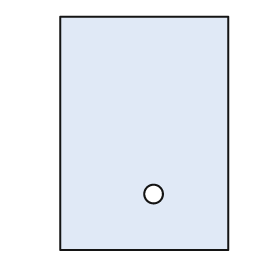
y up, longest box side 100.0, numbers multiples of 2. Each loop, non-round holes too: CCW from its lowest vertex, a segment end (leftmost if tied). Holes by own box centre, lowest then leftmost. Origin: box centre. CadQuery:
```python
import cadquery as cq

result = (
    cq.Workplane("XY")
    .moveTo(-36.0, -50.0)
    .lineTo(36.0, -50.0)
    .lineTo(36.0, 50.0)
    .lineTo(-36.0, 50.0)
    .close()
    .moveTo(4.0, -26.0)
    .circle(4.0)
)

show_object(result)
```